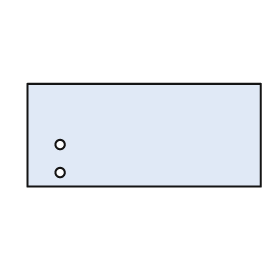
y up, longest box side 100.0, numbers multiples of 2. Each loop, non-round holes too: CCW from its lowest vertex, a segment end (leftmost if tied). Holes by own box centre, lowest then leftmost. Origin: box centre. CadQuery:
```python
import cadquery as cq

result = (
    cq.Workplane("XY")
    .moveTo(-50.0, -22.0)
    .lineTo(50.0, -22.0)
    .lineTo(50.0, 22.0)
    .lineTo(-50.0, 22.0)
    .close()
    .moveTo(-36.0, -16.0)
    .circle(2.0)
    .moveTo(-36.0, -4.0)
    .circle(2.0)
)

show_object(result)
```